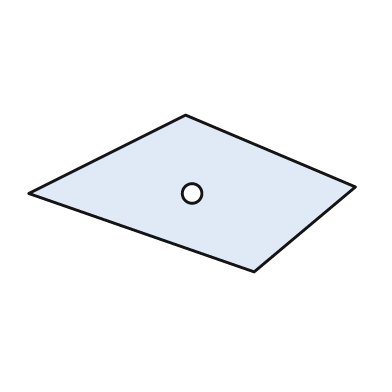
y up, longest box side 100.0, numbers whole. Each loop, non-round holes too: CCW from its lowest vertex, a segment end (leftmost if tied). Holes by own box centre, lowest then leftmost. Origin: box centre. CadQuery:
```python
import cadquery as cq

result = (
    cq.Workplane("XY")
    .moveTo(19.0, -24.0)
    .lineTo(50.0, 2.0)
    .lineTo(-2.0, 24.0)
    .lineTo(-50.0, 0.0)
    .close()
    .moveTo(0.0, 0.0)
    .circle(3.0)
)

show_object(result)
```